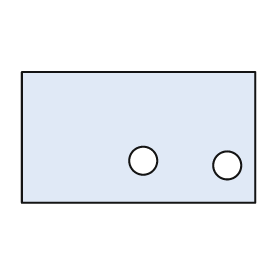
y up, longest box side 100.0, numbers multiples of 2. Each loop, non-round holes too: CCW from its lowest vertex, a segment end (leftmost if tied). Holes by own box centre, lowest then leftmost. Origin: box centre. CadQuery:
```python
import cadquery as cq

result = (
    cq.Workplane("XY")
    .moveTo(-50.0, -28.0)
    .lineTo(50.0, -28.0)
    .lineTo(50.0, 28.0)
    .lineTo(-50.0, 28.0)
    .close()
    .moveTo(38.0, -12.0)
    .circle(6.0)
    .moveTo(2.0, -10.0)
    .circle(6.0)
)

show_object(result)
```